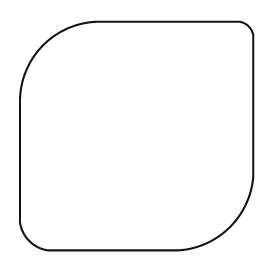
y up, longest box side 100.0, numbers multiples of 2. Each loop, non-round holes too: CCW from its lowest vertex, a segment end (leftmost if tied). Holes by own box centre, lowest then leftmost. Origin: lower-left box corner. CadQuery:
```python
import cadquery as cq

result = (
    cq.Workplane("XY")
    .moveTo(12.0, 0.0)
    .lineTo(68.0, 0.0)
    .threePointArc((90.0, 10.0), (100.0, 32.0))
    .lineTo(100.0, 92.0)
    .threePointArc((98.0, 96.0), (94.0, 98.0))
    .lineTo(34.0, 98.0)
    .threePointArc((10.0, 88.0), (0.0, 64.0))
    .lineTo(0.0, 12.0)
    .threePointArc((4.0, 4.0), (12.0, 0.0))
    .close()
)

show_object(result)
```